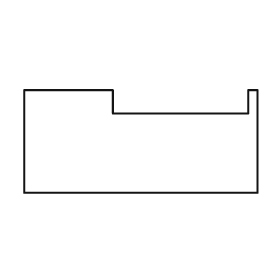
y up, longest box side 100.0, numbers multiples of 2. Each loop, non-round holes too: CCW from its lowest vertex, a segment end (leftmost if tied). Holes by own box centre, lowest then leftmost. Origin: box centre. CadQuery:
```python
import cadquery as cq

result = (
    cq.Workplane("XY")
    .moveTo(-50.0, -22.0)
    .lineTo(50.0, -22.0)
    .lineTo(50.0, 22.0)
    .lineTo(46.0, 22.0)
    .lineTo(46.0, 12.0)
    .lineTo(-12.0, 12.0)
    .lineTo(-12.0, 22.0)
    .lineTo(-50.0, 22.0)
    .close()
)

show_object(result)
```